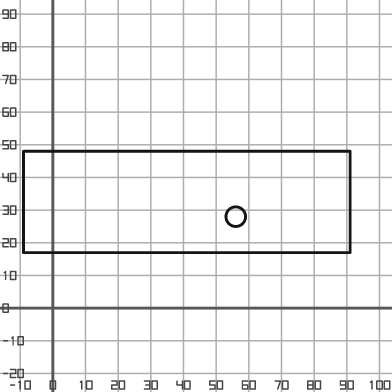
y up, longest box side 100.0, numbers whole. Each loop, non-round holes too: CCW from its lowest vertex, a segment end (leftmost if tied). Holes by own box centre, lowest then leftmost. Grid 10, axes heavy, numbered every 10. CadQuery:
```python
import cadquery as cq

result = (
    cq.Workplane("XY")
    .moveTo(-9.0, 17.0)
    .lineTo(91.0, 17.0)
    .lineTo(91.0, 48.0)
    .lineTo(-9.0, 48.0)
    .close()
    .moveTo(56.0, 28.0)
    .circle(3.0)
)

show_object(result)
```